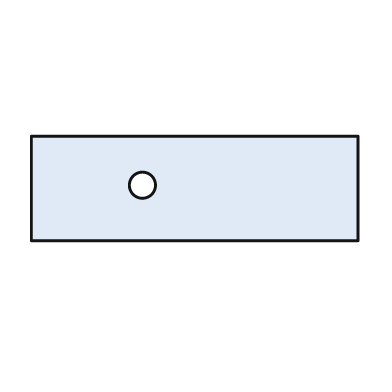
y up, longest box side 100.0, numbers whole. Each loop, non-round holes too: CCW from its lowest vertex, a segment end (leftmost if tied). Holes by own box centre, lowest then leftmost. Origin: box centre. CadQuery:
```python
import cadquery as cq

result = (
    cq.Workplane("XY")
    .moveTo(-50.0, -16.0)
    .lineTo(50.0, -16.0)
    .lineTo(50.0, 16.0)
    .lineTo(-50.0, 16.0)
    .close()
    .moveTo(-16.0, 1.0)
    .circle(4.0)
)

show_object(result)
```